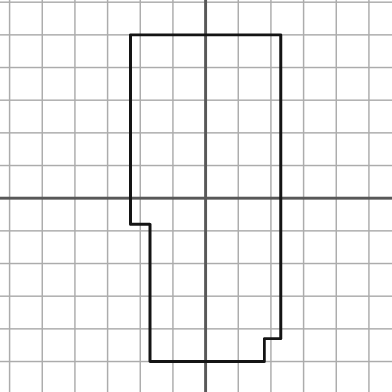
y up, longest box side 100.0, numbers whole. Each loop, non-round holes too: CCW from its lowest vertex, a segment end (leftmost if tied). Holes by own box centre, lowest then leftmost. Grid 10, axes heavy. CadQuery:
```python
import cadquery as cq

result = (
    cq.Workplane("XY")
    .moveTo(-17.0, -50.0)
    .lineTo(18.0, -50.0)
    .lineTo(18.0, -43.0)
    .lineTo(23.0, -43.0)
    .lineTo(23.0, 50.0)
    .lineTo(-23.0, 50.0)
    .lineTo(-23.0, -8.0)
    .lineTo(-17.0, -8.0)
    .close()
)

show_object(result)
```